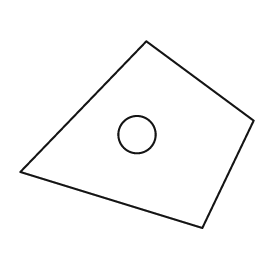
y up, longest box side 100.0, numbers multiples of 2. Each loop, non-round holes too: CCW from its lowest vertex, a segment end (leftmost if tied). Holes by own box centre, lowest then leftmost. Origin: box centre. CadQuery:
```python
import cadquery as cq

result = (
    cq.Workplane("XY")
    .moveTo(28.0, -40.0)
    .lineTo(50.0, 6.0)
    .lineTo(4.0, 40.0)
    .lineTo(-50.0, -16.0)
    .close()
    .moveTo(0.0, 0.0)
    .circle(8.0)
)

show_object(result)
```